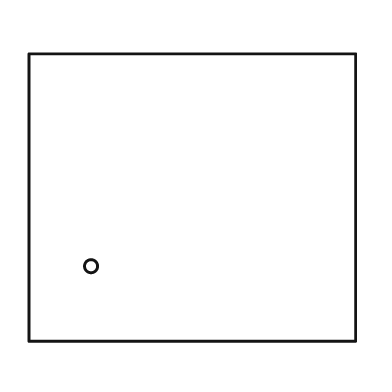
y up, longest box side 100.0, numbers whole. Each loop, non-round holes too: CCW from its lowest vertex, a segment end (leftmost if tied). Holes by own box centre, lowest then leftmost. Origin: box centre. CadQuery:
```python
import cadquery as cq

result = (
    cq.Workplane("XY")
    .moveTo(-50.0, -44.0)
    .lineTo(50.0, -44.0)
    .lineTo(50.0, 44.0)
    .lineTo(-50.0, 44.0)
    .close()
    .moveTo(-31.0, -21.0)
    .circle(2.0)
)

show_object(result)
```